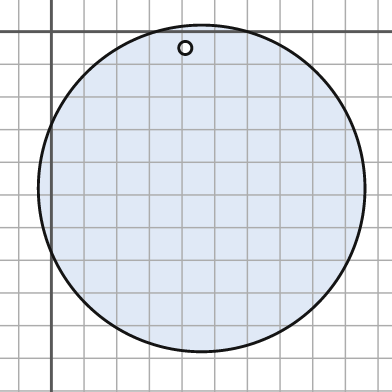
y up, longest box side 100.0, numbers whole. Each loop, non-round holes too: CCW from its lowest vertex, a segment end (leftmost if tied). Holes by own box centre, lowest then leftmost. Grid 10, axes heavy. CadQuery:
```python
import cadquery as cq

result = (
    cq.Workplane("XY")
    .moveTo(46.0, -48.0)
    .circle(50.0)
    .moveTo(41.0, -5.0)
    .circle(2.0)
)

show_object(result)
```